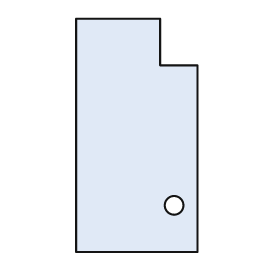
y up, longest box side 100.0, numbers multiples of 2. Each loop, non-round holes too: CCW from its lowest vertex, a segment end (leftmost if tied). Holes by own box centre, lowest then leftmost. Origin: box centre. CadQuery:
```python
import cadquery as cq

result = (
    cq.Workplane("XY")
    .moveTo(-26.0, -50.0)
    .lineTo(26.0, -50.0)
    .lineTo(26.0, 30.0)
    .lineTo(10.0, 30.0)
    .lineTo(10.0, 50.0)
    .lineTo(-26.0, 50.0)
    .close()
    .moveTo(16.0, -30.0)
    .circle(4.0)
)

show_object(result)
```